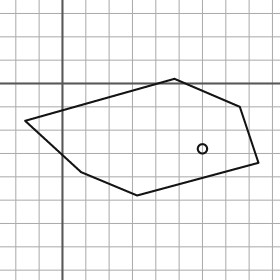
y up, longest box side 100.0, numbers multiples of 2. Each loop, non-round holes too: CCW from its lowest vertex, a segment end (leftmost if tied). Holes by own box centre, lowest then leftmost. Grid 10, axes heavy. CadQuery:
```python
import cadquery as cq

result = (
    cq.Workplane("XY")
    .moveTo(32.0, -48.0)
    .lineTo(84.0, -34.0)
    .lineTo(76.0, -10.0)
    .lineTo(48.0, 2.0)
    .lineTo(-16.0, -16.0)
    .lineTo(8.0, -38.0)
    .close()
    .moveTo(60.0, -28.0)
    .circle(2.0)
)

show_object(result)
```